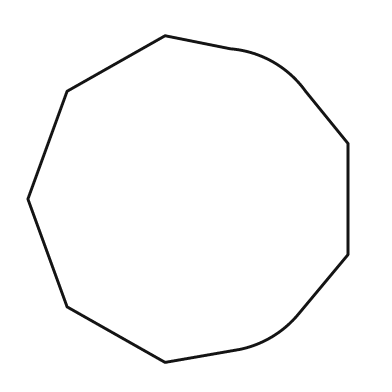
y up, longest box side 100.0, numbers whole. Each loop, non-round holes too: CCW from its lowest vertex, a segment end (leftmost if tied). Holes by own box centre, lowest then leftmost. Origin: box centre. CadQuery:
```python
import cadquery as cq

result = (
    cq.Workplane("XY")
    .moveTo(-7.0, -50.0)
    .lineTo(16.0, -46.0)
    .threePointArc((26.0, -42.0), (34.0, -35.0))
    .lineTo(49.0, -17.0)
    .lineTo(49.0, 17.0)
    .lineTo(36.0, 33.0)
    .threePointArc((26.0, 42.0), (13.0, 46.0))
    .lineTo(-7.0, 50.0)
    .lineTo(-37.0, 33.0)
    .lineTo(-49.0, 0.0)
    .lineTo(-37.0, -33.0)
    .close()
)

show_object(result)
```